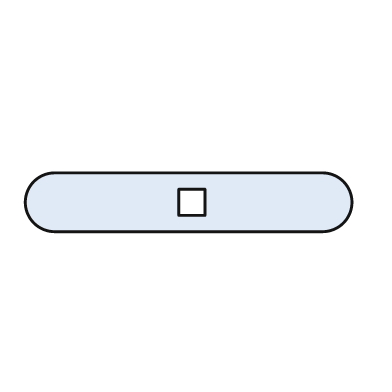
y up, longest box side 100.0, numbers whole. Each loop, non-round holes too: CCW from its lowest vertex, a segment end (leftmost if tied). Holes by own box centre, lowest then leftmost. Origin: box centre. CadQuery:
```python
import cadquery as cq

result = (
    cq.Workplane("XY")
    .moveTo(-41.0, -9.0)
    .lineTo(41.0, -9.0)
    .threePointArc((50.0, 0.0), (41.0, 9.0))
    .lineTo(-41.0, 9.0)
    .threePointArc((-50.0, 0.0), (-41.0, -9.0))
    .close()
    .moveTo(-3.0, -4.0)
    .lineTo(5.0, -4.0)
    .lineTo(5.0, 4.0)
    .lineTo(-3.0, 4.0)
    .close()
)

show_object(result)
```